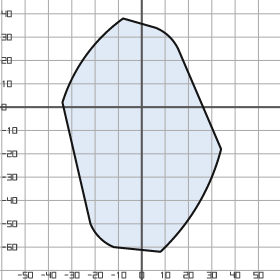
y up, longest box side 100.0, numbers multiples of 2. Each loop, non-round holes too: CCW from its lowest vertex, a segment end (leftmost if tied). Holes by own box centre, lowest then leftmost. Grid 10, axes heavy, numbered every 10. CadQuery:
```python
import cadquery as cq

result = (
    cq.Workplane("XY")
    .moveTo(8.0, -62.0)
    .threePointArc((24.0, -42.0), (34.0, -18.0))
    .lineTo(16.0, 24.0)
    .threePointArc((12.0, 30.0), (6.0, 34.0))
    .lineTo(-8.0, 38.0)
    .threePointArc((-24.0, 22.0), (-34.0, 2.0))
    .lineTo(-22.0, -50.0)
    .threePointArc((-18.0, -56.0), (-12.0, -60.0))
    .close()
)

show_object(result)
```